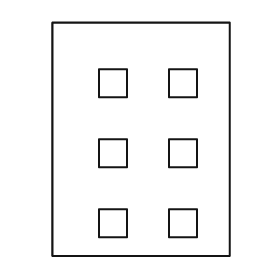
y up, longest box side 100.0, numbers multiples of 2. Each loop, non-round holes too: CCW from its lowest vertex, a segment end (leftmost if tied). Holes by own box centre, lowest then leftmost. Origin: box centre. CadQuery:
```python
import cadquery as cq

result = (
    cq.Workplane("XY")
    .moveTo(-38.0, -50.0)
    .lineTo(38.0, -50.0)
    .lineTo(38.0, 50.0)
    .lineTo(-38.0, 50.0)
    .close()
    .moveTo(-18.0, -42.0)
    .lineTo(-6.0, -42.0)
    .lineTo(-6.0, -30.0)
    .lineTo(-18.0, -30.0)
    .close()
    .moveTo(12.0, -42.0)
    .lineTo(24.0, -42.0)
    .lineTo(24.0, -30.0)
    .lineTo(12.0, -30.0)
    .close()
    .moveTo(-18.0, -12.0)
    .lineTo(-6.0, -12.0)
    .lineTo(-6.0, 0.0)
    .lineTo(-18.0, 0.0)
    .close()
    .moveTo(12.0, -12.0)
    .lineTo(24.0, -12.0)
    .lineTo(24.0, 0.0)
    .lineTo(12.0, 0.0)
    .close()
    .moveTo(-18.0, 18.0)
    .lineTo(-6.0, 18.0)
    .lineTo(-6.0, 30.0)
    .lineTo(-18.0, 30.0)
    .close()
    .moveTo(12.0, 18.0)
    .lineTo(24.0, 18.0)
    .lineTo(24.0, 30.0)
    .lineTo(12.0, 30.0)
    .close()
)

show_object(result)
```